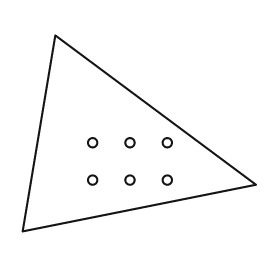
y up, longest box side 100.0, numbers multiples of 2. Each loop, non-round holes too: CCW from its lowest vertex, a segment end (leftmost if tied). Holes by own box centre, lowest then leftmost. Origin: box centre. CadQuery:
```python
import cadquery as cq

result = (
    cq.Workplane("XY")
    .moveTo(-50.0, -42.0)
    .lineTo(50.0, -22.0)
    .lineTo(-36.0, 42.0)
    .close()
    .moveTo(-20.0, -20.0)
    .circle(2.0)
    .moveTo(-4.0, -20.0)
    .circle(2.0)
    .moveTo(12.0, -20.0)
    .circle(2.0)
    .moveTo(-20.0, -4.0)
    .circle(2.0)
    .moveTo(-4.0, -4.0)
    .circle(2.0)
    .moveTo(12.0, -4.0)
    .circle(2.0)
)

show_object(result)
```